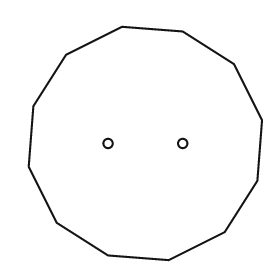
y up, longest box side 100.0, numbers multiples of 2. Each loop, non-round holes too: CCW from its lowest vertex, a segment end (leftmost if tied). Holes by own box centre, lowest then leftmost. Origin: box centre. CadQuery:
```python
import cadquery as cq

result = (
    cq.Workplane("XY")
    .moveTo(10.0, -50.0)
    .lineTo(34.0, -38.0)
    .lineTo(48.0, -16.0)
    .lineTo(50.0, 10.0)
    .lineTo(38.0, 34.0)
    .lineTo(16.0, 48.0)
    .lineTo(-10.0, 50.0)
    .lineTo(-34.0, 38.0)
    .lineTo(-48.0, 16.0)
    .lineTo(-50.0, -10.0)
    .lineTo(-38.0, -34.0)
    .lineTo(-16.0, -48.0)
    .close()
    .moveTo(-16.0, 0.0)
    .circle(2.0)
    .moveTo(16.0, 0.0)
    .circle(2.0)
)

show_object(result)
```